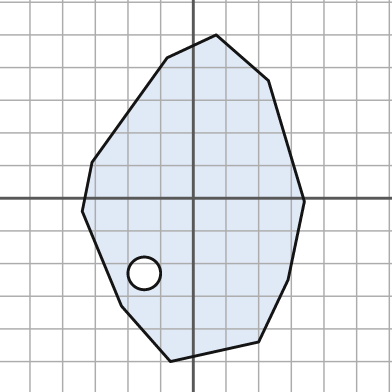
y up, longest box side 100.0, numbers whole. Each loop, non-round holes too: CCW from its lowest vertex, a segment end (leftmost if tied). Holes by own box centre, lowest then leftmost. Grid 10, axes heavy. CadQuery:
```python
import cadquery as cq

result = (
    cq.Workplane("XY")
    .moveTo(-7.0, -50.0)
    .lineTo(20.0, -44.0)
    .lineTo(29.0, -25.0)
    .lineTo(34.0, -1.0)
    .lineTo(23.0, 36.0)
    .lineTo(7.0, 50.0)
    .lineTo(-8.0, 43.0)
    .lineTo(-31.0, 11.0)
    .lineTo(-34.0, -4.0)
    .lineTo(-22.0, -33.0)
    .close()
    .moveTo(-15.0, -23.0)
    .circle(5.0)
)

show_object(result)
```